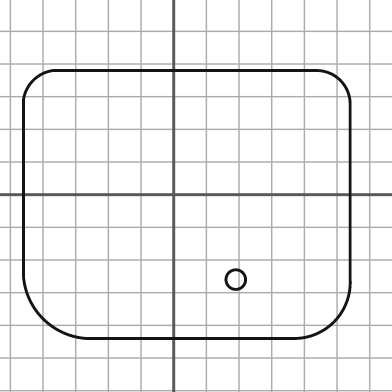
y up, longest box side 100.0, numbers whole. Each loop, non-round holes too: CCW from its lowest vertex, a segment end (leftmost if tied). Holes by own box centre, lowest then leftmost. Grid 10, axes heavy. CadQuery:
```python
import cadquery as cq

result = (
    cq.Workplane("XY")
    .moveTo(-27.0, -44.0)
    .lineTo(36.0, -44.0)
    .threePointArc((49.0, -39.0), (54.0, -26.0))
    .lineTo(54.0, 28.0)
    .threePointArc((51.0, 35.0), (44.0, 38.0))
    .lineTo(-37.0, 38.0)
    .threePointArc((-43.0, 35.0), (-46.0, 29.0))
    .lineTo(-46.0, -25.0)
    .threePointArc((-40.0, -38.0), (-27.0, -44.0))
    .close()
    .moveTo(19.0, -26.0)
    .circle(3.0)
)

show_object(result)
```